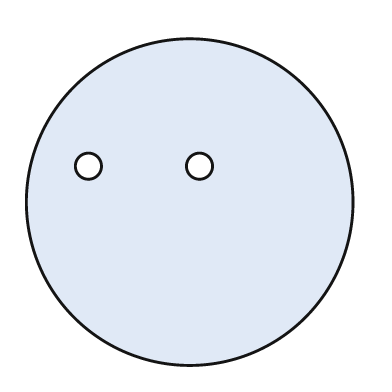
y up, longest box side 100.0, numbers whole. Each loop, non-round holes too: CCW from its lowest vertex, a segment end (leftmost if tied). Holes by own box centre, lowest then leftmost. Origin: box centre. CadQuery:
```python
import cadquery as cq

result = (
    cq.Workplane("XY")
    .moveTo(0.0, 0.0)
    .circle(50.0)
    .moveTo(-31.0, 11.0)
    .circle(4.0)
    .moveTo(3.0, 11.0)
    .circle(4.0)
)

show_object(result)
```